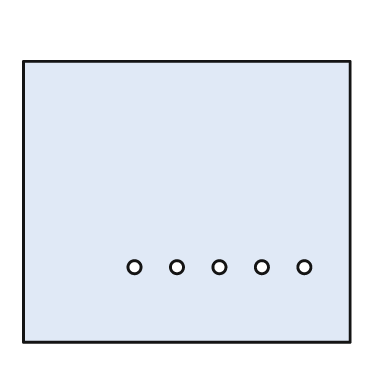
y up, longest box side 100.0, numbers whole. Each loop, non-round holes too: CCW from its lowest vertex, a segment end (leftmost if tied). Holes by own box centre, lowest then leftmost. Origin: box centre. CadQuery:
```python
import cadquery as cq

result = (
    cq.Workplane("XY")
    .moveTo(-50.0, -43.0)
    .lineTo(50.0, -43.0)
    .lineTo(50.0, 43.0)
    .lineTo(-50.0, 43.0)
    .close()
    .moveTo(-16.0, -20.0)
    .circle(2.0)
    .moveTo(-3.0, -20.0)
    .circle(2.0)
    .moveTo(10.0, -20.0)
    .circle(2.0)
    .moveTo(23.0, -20.0)
    .circle(2.0)
    .moveTo(36.0, -20.0)
    .circle(2.0)
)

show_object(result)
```